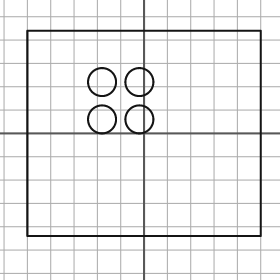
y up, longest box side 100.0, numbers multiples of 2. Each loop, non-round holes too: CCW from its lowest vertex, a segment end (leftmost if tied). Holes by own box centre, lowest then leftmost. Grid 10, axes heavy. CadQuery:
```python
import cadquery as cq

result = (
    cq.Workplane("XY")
    .moveTo(-50.0, -44.0)
    .lineTo(50.0, -44.0)
    .lineTo(50.0, 44.0)
    .lineTo(-50.0, 44.0)
    .close()
    .moveTo(-18.0, 6.0)
    .circle(6.0)
    .moveTo(-2.0, 6.0)
    .circle(6.0)
    .moveTo(-18.0, 22.0)
    .circle(6.0)
    .moveTo(-2.0, 22.0)
    .circle(6.0)
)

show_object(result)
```